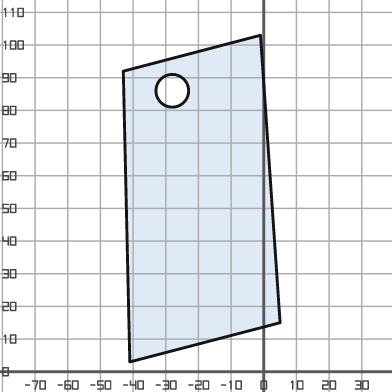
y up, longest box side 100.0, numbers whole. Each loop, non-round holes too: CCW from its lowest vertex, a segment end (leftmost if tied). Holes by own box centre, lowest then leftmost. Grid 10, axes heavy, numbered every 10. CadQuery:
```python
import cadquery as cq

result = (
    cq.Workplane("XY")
    .moveTo(-41.0, 3.0)
    .lineTo(5.0, 15.0)
    .lineTo(-1.0, 103.0)
    .lineTo(-43.0, 92.0)
    .close()
    .moveTo(-28.0, 86.0)
    .circle(5.0)
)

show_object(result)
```